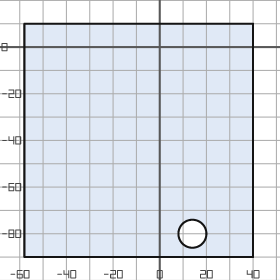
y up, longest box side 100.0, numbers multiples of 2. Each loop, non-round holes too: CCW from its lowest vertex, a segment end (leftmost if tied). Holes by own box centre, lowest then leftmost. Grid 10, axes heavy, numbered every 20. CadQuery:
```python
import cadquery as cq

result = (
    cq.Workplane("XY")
    .moveTo(-58.0, -90.0)
    .lineTo(40.0, -90.0)
    .lineTo(40.0, 10.0)
    .lineTo(-58.0, 10.0)
    .close()
    .moveTo(14.0, -80.0)
    .circle(6.0)
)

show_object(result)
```